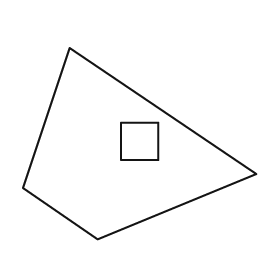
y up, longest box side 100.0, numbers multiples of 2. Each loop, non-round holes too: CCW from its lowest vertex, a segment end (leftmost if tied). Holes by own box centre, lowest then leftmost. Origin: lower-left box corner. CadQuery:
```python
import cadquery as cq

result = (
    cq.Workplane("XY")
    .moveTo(32.0, 0.0)
    .lineTo(100.0, 28.0)
    .lineTo(20.0, 82.0)
    .lineTo(0.0, 22.0)
    .close()
    .moveTo(42.0, 34.0)
    .lineTo(58.0, 34.0)
    .lineTo(58.0, 50.0)
    .lineTo(42.0, 50.0)
    .close()
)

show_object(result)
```